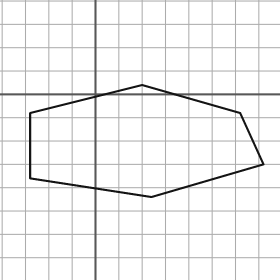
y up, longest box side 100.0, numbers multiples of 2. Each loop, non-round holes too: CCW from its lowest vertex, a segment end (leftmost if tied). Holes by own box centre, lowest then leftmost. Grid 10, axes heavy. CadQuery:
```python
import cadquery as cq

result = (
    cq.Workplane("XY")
    .moveTo(24.0, -44.0)
    .lineTo(72.0, -30.0)
    .lineTo(62.0, -8.0)
    .lineTo(20.0, 4.0)
    .lineTo(-28.0, -8.0)
    .lineTo(-28.0, -36.0)
    .close()
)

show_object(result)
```